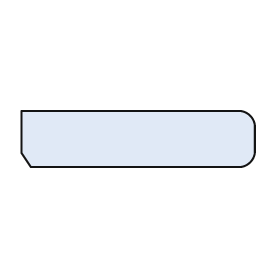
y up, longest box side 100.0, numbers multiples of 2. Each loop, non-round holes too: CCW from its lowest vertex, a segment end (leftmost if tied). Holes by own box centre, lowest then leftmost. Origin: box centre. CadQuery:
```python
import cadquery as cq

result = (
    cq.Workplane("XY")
    .moveTo(-46.0, -12.0)
    .lineTo(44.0, -12.0)
    .threePointArc((48.0, -10.0), (50.0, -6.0))
    .lineTo(50.0, 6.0)
    .threePointArc((48.0, 10.0), (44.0, 12.0))
    .lineTo(-50.0, 12.0)
    .lineTo(-50.0, -6.0)
    .close()
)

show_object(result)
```